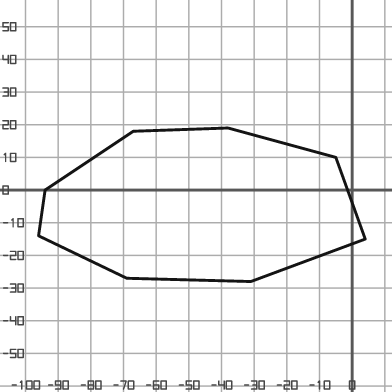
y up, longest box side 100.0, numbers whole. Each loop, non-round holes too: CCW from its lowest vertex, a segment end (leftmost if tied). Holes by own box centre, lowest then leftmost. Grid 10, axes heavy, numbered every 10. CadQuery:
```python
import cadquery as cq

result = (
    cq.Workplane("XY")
    .moveTo(-31.0, -28.0)
    .lineTo(4.0, -15.0)
    .lineTo(-5.0, 10.0)
    .lineTo(-38.0, 19.0)
    .lineTo(-67.0, 18.0)
    .lineTo(-94.0, 0.0)
    .lineTo(-96.0, -14.0)
    .lineTo(-69.0, -27.0)
    .close()
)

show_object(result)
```